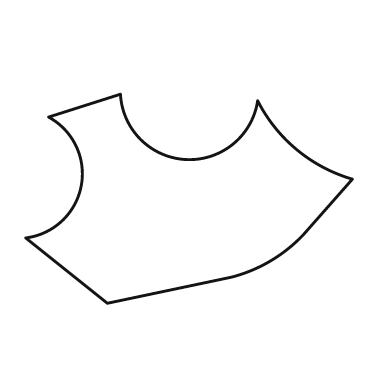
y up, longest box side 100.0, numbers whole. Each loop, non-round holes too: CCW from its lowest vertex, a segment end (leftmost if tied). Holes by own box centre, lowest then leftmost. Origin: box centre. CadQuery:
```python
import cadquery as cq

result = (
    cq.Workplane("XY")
    .moveTo(-25.0, -32.0)
    .lineTo(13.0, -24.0)
    .threePointArc((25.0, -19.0), (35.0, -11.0))
    .lineTo(50.0, 6.0)
    .threePointArc((33.0, 15.0), (21.0, 30.0))
    .threePointArc((-1.0, 12.0), (-21.0, 32.0))
    .lineTo(-43.0, 25.0)
    .threePointArc((-33.0, 4.0), (-50.0, -12.0))
    .close()
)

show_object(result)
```